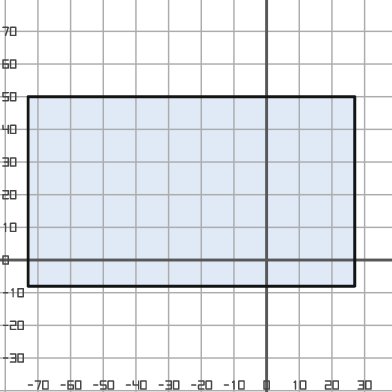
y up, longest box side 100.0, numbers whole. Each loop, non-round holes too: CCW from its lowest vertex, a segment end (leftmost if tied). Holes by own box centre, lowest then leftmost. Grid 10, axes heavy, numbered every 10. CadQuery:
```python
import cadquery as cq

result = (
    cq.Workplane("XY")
    .moveTo(-73.0, -8.0)
    .lineTo(27.0, -8.0)
    .lineTo(27.0, 50.0)
    .lineTo(-73.0, 50.0)
    .close()
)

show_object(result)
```